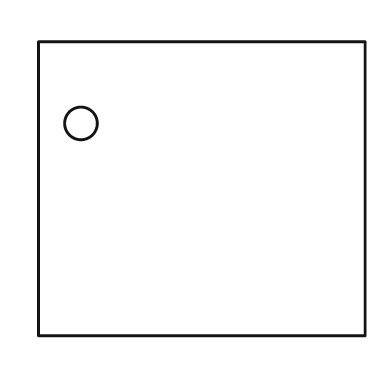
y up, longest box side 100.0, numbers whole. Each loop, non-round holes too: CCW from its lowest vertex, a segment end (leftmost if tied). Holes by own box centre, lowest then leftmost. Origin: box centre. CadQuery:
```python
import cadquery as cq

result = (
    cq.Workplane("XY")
    .moveTo(-50.0, -45.0)
    .lineTo(50.0, -45.0)
    .lineTo(50.0, 45.0)
    .lineTo(-50.0, 45.0)
    .close()
    .moveTo(-37.0, 20.0)
    .circle(5.0)
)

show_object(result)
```